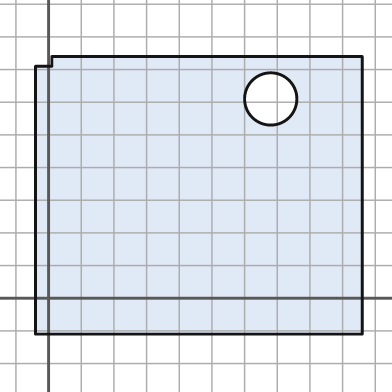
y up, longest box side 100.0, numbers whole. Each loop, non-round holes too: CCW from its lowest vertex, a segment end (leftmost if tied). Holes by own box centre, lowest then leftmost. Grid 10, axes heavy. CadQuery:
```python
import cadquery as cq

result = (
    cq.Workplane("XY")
    .moveTo(-4.0, -11.0)
    .lineTo(96.0, -11.0)
    .lineTo(96.0, 74.0)
    .lineTo(1.0, 74.0)
    .lineTo(1.0, 71.0)
    .lineTo(-4.0, 71.0)
    .close()
    .moveTo(68.0, 61.0)
    .circle(8.0)
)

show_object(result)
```